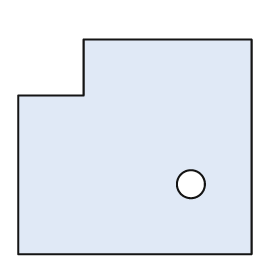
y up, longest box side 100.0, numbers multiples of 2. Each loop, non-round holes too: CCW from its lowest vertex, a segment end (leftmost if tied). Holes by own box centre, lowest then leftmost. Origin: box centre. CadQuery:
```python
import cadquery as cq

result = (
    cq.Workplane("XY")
    .moveTo(-50.0, -46.0)
    .lineTo(50.0, -46.0)
    .lineTo(50.0, 46.0)
    .lineTo(-22.0, 46.0)
    .lineTo(-22.0, 22.0)
    .lineTo(-50.0, 22.0)
    .close()
    .moveTo(24.0, -16.0)
    .circle(6.0)
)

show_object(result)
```